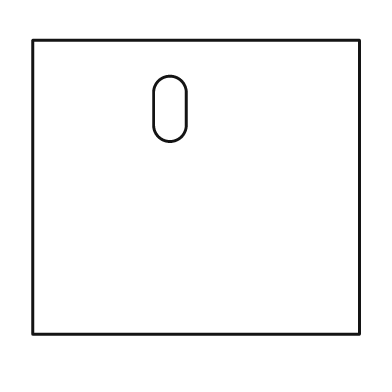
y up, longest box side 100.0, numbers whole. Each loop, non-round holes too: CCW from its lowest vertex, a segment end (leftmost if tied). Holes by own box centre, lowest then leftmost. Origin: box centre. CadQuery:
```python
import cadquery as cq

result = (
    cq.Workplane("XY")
    .moveTo(-50.0, -45.0)
    .lineTo(50.0, -45.0)
    .lineTo(50.0, 45.0)
    .lineTo(-50.0, 45.0)
    .close()
    .moveTo(-13.0, 19.0)
    .threePointArc((-8.0, 14.0), (-3.0, 19.0))
    .lineTo(-3.0, 29.0)
    .threePointArc((-8.0, 34.0), (-13.0, 29.0))
    .close()
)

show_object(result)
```